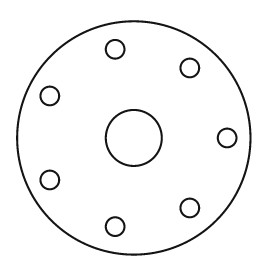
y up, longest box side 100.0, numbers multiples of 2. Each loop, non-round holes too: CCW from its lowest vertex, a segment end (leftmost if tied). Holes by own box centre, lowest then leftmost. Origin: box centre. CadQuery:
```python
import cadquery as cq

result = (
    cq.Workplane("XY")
    .moveTo(0.0, 0.0)
    .circle(50.0)
    .moveTo(-8.0, -38.0)
    .circle(4.0)
    .moveTo(24.0, -30.0)
    .circle(4.0)
    .moveTo(-36.0, -18.0)
    .circle(4.0)
    .moveTo(0.0, 0.0)
    .circle(12.0)
    .moveTo(40.0, 0.0)
    .circle(4.0)
    .moveTo(-36.0, 18.0)
    .circle(4.0)
    .moveTo(24.0, 30.0)
    .circle(4.0)
    .moveTo(-8.0, 38.0)
    .circle(4.0)
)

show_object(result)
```